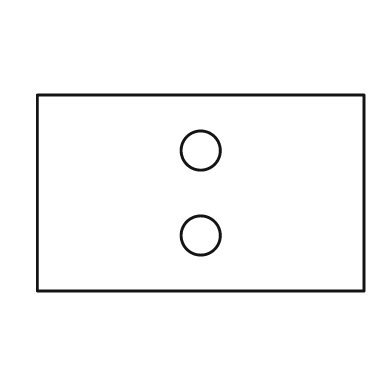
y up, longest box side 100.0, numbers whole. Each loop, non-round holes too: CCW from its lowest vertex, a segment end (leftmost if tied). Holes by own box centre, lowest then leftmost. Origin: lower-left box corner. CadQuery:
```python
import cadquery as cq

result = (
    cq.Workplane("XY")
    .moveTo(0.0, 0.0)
    .lineTo(100.0, 0.0)
    .lineTo(100.0, 60.0)
    .lineTo(0.0, 60.0)
    .close()
    .moveTo(50.0, 17.0)
    .circle(6.0)
    .moveTo(50.0, 43.0)
    .circle(6.0)
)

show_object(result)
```